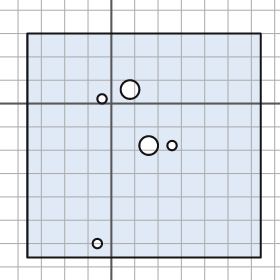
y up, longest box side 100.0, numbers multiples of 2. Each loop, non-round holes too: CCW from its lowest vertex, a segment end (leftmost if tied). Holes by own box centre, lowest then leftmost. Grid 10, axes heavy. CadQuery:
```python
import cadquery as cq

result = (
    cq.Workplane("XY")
    .moveTo(-36.0, -66.0)
    .lineTo(64.0, -66.0)
    .lineTo(64.0, 30.0)
    .lineTo(-36.0, 30.0)
    .close()
    .moveTo(-6.0, -60.0)
    .circle(2.0)
    .moveTo(16.0, -18.0)
    .circle(4.0)
    .moveTo(26.0, -18.0)
    .circle(2.0)
    .moveTo(-4.0, 2.0)
    .circle(2.0)
    .moveTo(8.0, 6.0)
    .circle(4.0)
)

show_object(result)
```